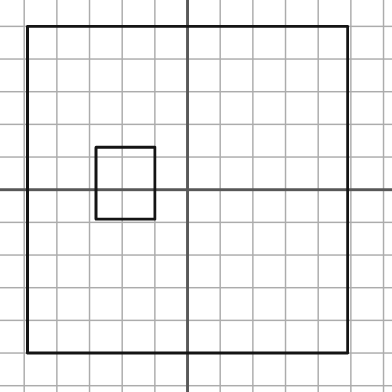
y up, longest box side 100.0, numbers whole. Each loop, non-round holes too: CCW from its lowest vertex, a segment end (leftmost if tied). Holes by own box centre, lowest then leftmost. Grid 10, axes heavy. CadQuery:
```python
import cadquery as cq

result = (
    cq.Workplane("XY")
    .moveTo(-49.0, -50.0)
    .lineTo(49.0, -50.0)
    .lineTo(49.0, 50.0)
    .lineTo(-49.0, 50.0)
    .close()
    .moveTo(-28.0, -9.0)
    .lineTo(-10.0, -9.0)
    .lineTo(-10.0, 13.0)
    .lineTo(-28.0, 13.0)
    .close()
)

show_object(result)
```